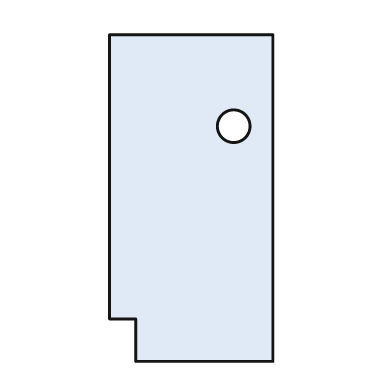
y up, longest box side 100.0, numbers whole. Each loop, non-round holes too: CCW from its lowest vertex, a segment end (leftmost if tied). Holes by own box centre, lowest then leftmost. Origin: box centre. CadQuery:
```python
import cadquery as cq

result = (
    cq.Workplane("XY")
    .moveTo(-17.0, -50.0)
    .lineTo(25.0, -50.0)
    .lineTo(25.0, 50.0)
    .lineTo(-25.0, 50.0)
    .lineTo(-25.0, -37.0)
    .lineTo(-17.0, -37.0)
    .close()
    .moveTo(13.0, 22.0)
    .circle(5.0)
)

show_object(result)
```